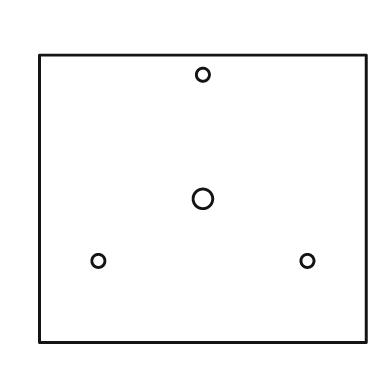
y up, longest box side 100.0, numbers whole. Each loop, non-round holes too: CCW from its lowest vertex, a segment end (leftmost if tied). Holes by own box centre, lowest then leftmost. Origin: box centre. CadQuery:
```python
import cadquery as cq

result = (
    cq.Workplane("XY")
    .moveTo(-50.0, -44.0)
    .lineTo(50.0, -44.0)
    .lineTo(50.0, 44.0)
    .lineTo(-50.0, 44.0)
    .close()
    .moveTo(-32.0, -19.0)
    .circle(2.0)
    .moveTo(32.0, -19.0)
    .circle(2.0)
    .moveTo(0.0, 0.0)
    .circle(3.0)
    .moveTo(0.0, 38.0)
    .circle(2.0)
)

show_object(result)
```